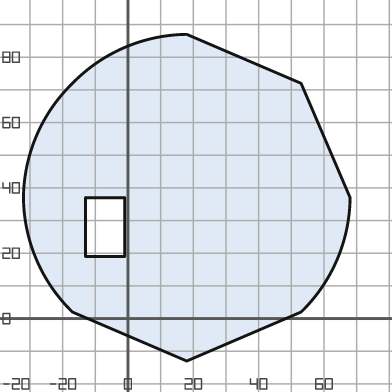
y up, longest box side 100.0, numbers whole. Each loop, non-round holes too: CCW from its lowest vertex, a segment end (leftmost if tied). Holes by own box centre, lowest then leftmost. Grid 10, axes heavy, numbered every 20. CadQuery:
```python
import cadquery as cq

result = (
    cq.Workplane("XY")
    .moveTo(18.0, -13.0)
    .lineTo(53.0, 2.0)
    .threePointArc((64.0, 18.0), (68.0, 37.0))
    .lineTo(53.0, 72.0)
    .lineTo(18.0, 87.0)
    .threePointArc((-1.0, 83.0), (-17.0, 72.0))
    .threePointArc((-28.0, 56.0), (-32.0, 37.0))
    .threePointArc((-28.0, 18.0), (-17.0, 2.0))
    .close()
    .moveTo(-13.0, 19.0)
    .lineTo(-1.0, 19.0)
    .lineTo(-1.0, 37.0)
    .lineTo(-13.0, 37.0)
    .close()
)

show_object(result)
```